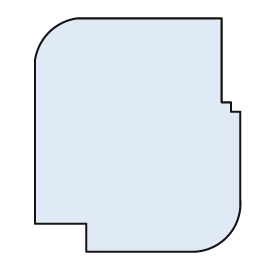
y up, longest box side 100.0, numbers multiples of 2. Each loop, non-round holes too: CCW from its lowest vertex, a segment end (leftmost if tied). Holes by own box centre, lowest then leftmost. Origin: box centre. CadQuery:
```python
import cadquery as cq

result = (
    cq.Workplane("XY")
    .moveTo(-22.0, -50.0)
    .lineTo(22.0, -50.0)
    .threePointArc((38.0, -44.0), (44.0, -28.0))
    .lineTo(44.0, 10.0)
    .lineTo(40.0, 10.0)
    .lineTo(40.0, 14.0)
    .lineTo(36.0, 14.0)
    .lineTo(36.0, 50.0)
    .lineTo(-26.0, 50.0)
    .threePointArc((-38.0, 44.0), (-44.0, 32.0))
    .lineTo(-44.0, -38.0)
    .lineTo(-22.0, -38.0)
    .close()
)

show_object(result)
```